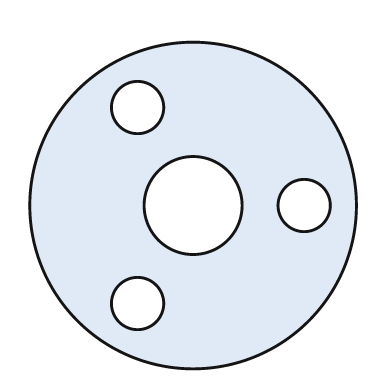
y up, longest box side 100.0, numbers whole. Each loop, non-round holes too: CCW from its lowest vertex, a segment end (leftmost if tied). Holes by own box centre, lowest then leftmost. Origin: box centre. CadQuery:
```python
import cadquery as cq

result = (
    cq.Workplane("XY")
    .moveTo(0.0, 0.0)
    .circle(50.0)
    .moveTo(-17.0, -30.0)
    .circle(8.0)
    .moveTo(0.0, 0.0)
    .circle(15.0)
    .moveTo(34.0, 0.0)
    .circle(8.0)
    .moveTo(-17.0, 30.0)
    .circle(8.0)
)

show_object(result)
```